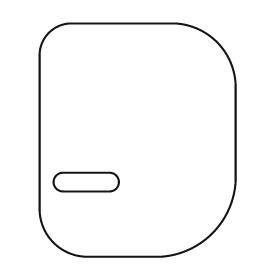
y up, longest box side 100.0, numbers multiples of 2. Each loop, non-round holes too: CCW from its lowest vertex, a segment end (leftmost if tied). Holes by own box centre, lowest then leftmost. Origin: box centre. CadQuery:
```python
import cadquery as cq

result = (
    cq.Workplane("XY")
    .moveTo(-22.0, -50.0)
    .lineTo(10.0, -50.0)
    .threePointArc((32.0, -40.0), (42.0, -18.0))
    .lineTo(42.0, 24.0)
    .threePointArc((34.0, 42.0), (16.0, 50.0))
    .lineTo(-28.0, 50.0)
    .threePointArc((-38.0, 46.0), (-42.0, 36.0))
    .lineTo(-42.0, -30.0)
    .threePointArc((-36.0, -44.0), (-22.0, -50.0))
    .close()
    .moveTo(-32.0, -22.0)
    .lineTo(-12.0, -22.0)
    .threePointArc((-8.0, -18.0), (-12.0, -14.0))
    .lineTo(-32.0, -14.0)
    .threePointArc((-36.0, -18.0), (-32.0, -22.0))
    .close()
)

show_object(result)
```